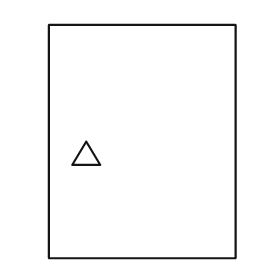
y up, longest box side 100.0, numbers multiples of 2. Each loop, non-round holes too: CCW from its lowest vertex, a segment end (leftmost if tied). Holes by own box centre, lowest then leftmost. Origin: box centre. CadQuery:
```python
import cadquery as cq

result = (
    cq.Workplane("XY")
    .moveTo(-40.0, -50.0)
    .lineTo(40.0, -50.0)
    .lineTo(40.0, 50.0)
    .lineTo(-40.0, 50.0)
    .close()
    .moveTo(-30.0, -10.0)
    .lineTo(-18.0, -10.0)
    .lineTo(-24.0, 0.0)
    .close()
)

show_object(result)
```